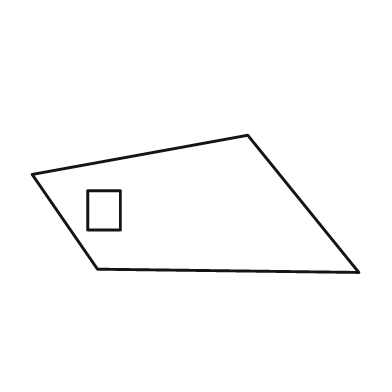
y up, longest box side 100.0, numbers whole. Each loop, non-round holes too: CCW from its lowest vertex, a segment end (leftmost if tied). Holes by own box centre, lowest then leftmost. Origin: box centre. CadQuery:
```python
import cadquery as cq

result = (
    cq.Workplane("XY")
    .moveTo(50.0, -21.0)
    .lineTo(16.0, 21.0)
    .lineTo(-50.0, 9.0)
    .lineTo(-30.0, -20.0)
    .close()
    .moveTo(-33.0, -8.0)
    .lineTo(-23.0, -8.0)
    .lineTo(-23.0, 4.0)
    .lineTo(-33.0, 4.0)
    .close()
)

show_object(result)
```